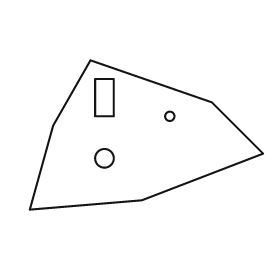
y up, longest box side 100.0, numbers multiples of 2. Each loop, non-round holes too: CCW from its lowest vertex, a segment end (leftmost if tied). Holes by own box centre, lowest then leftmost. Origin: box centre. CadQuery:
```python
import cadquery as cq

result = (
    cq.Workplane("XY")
    .moveTo(-50.0, -32.0)
    .lineTo(-2.0, -28.0)
    .lineTo(50.0, -8.0)
    .lineTo(28.0, 14.0)
    .lineTo(-24.0, 32.0)
    .lineTo(-40.0, 4.0)
    .close()
    .moveTo(-18.0, -10.0)
    .circle(4.0)
    .moveTo(10.0, 8.0)
    .circle(2.0)
    .moveTo(-22.0, 8.0)
    .lineTo(-14.0, 8.0)
    .lineTo(-14.0, 24.0)
    .lineTo(-22.0, 24.0)
    .close()
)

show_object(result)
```